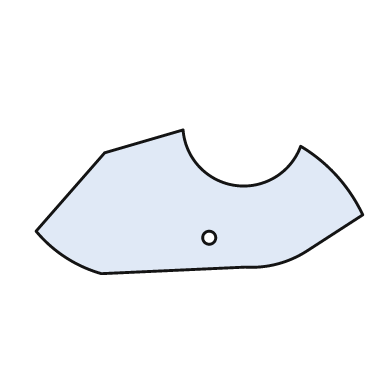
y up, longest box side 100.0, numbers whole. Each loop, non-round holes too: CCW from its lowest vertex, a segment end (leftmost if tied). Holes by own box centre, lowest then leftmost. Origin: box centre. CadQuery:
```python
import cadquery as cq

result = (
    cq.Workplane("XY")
    .moveTo(-30.0, -22.0)
    .lineTo(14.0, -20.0)
    .threePointArc((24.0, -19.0), (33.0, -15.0))
    .lineTo(50.0, -4.0)
    .threePointArc((42.0, 8.0), (31.0, 17.0))
    .threePointArc((11.0, 5.0), (-5.0, 22.0))
    .lineTo(-29.0, 15.0)
    .lineTo(-50.0, -9.0)
    .threePointArc((-41.0, -17.0), (-30.0, -22.0))
    .close()
    .moveTo(3.0, -11.0)
    .circle(2.0)
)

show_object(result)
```